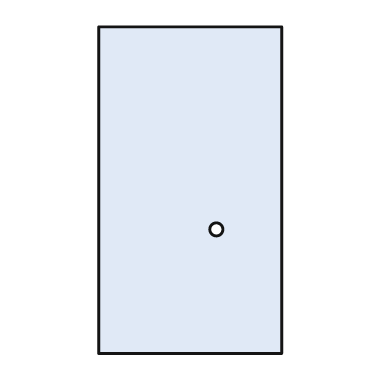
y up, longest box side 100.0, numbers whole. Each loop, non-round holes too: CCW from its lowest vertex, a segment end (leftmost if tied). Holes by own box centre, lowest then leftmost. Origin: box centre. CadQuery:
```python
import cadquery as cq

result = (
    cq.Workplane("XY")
    .moveTo(-28.0, -50.0)
    .lineTo(28.0, -50.0)
    .lineTo(28.0, 50.0)
    .lineTo(-28.0, 50.0)
    .close()
    .moveTo(8.0, -12.0)
    .circle(2.0)
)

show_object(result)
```